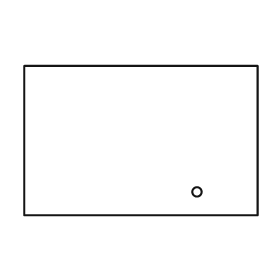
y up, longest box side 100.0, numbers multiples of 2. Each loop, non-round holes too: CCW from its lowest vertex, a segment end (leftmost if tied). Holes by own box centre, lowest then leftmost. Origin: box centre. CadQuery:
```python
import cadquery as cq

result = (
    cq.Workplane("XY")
    .moveTo(-50.0, -32.0)
    .lineTo(50.0, -32.0)
    .lineTo(50.0, 32.0)
    .lineTo(-50.0, 32.0)
    .close()
    .moveTo(24.0, -22.0)
    .circle(2.0)
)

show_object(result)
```